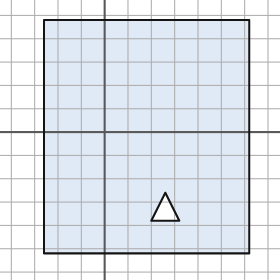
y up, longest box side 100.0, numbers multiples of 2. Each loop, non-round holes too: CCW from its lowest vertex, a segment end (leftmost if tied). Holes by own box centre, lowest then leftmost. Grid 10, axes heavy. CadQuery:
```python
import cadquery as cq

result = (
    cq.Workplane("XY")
    .moveTo(-26.0, -52.0)
    .lineTo(62.0, -52.0)
    .lineTo(62.0, 48.0)
    .lineTo(-26.0, 48.0)
    .close()
    .moveTo(20.0, -38.0)
    .lineTo(32.0, -38.0)
    .lineTo(26.0, -26.0)
    .close()
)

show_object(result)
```